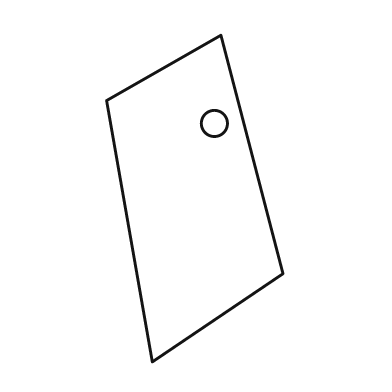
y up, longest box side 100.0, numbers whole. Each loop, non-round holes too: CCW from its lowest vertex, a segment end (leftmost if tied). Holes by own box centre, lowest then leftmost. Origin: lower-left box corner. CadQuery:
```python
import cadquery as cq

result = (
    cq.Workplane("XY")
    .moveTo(14.0, 0.0)
    .lineTo(54.0, 27.0)
    .lineTo(35.0, 100.0)
    .lineTo(0.0, 80.0)
    .close()
    .moveTo(33.0, 73.0)
    .circle(4.0)
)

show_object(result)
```